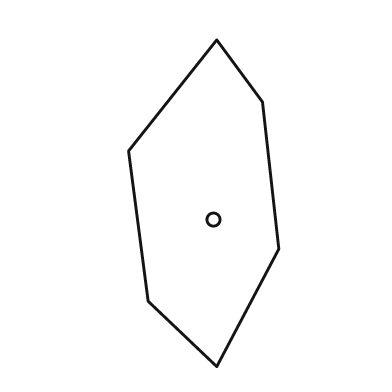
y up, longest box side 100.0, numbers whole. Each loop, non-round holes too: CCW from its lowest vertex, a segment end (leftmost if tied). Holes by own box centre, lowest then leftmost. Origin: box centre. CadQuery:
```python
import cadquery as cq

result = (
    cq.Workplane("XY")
    .moveTo(4.0, -50.0)
    .lineTo(23.0, -14.0)
    .lineTo(18.0, 31.0)
    .lineTo(4.0, 50.0)
    .lineTo(-23.0, 16.0)
    .lineTo(-17.0, -30.0)
    .close()
    .moveTo(3.0, -5.0)
    .circle(2.0)
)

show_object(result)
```